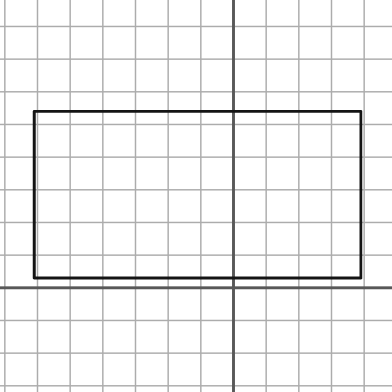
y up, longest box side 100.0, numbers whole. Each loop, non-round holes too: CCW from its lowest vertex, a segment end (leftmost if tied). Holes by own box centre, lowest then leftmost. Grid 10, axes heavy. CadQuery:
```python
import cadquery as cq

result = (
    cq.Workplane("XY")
    .moveTo(-61.0, 3.0)
    .lineTo(39.0, 3.0)
    .lineTo(39.0, 54.0)
    .lineTo(-61.0, 54.0)
    .close()
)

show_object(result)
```